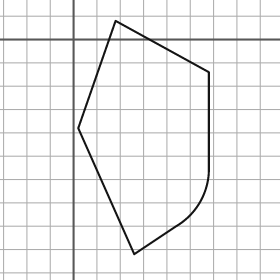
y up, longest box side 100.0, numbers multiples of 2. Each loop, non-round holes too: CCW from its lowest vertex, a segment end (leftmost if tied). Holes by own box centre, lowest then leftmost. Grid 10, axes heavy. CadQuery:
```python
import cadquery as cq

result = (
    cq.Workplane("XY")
    .moveTo(26.0, -92.0)
    .lineTo(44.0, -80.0)
    .threePointArc((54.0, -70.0), (58.0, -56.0))
    .lineTo(58.0, -14.0)
    .lineTo(18.0, 8.0)
    .lineTo(2.0, -38.0)
    .close()
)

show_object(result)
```